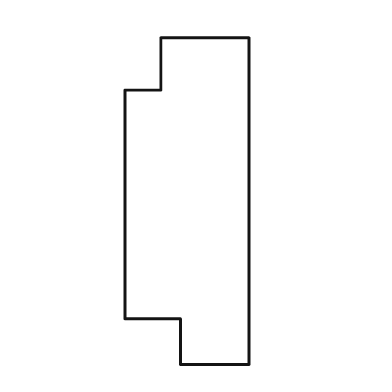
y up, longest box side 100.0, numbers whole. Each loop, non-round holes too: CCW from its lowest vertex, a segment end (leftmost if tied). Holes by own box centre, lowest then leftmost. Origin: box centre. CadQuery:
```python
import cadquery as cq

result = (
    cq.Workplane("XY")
    .moveTo(-2.0, -50.0)
    .lineTo(19.0, -50.0)
    .lineTo(19.0, 50.0)
    .lineTo(-8.0, 50.0)
    .lineTo(-8.0, 34.0)
    .lineTo(-19.0, 34.0)
    .lineTo(-19.0, -36.0)
    .lineTo(-2.0, -36.0)
    .close()
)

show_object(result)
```